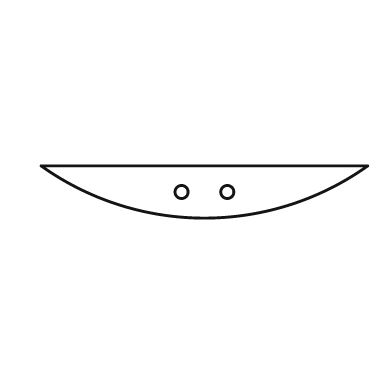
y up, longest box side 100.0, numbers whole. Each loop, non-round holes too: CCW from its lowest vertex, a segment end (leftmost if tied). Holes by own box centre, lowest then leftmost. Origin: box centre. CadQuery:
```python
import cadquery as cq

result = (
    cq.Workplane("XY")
    .moveTo(-50.0, 8.0)
    .threePointArc((0.0, -8.0), (50.0, 8.0))
    .close()
    .moveTo(-7.0, 0.0)
    .circle(2.0)
    .moveTo(7.0, 0.0)
    .circle(2.0)
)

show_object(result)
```